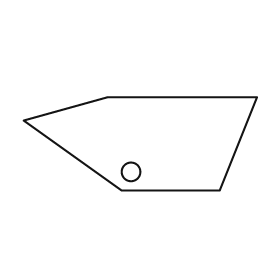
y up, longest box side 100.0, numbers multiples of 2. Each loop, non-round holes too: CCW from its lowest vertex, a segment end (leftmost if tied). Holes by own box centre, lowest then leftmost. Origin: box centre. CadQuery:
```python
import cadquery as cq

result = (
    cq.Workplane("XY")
    .moveTo(-8.0, -20.0)
    .lineTo(34.0, -20.0)
    .lineTo(50.0, 20.0)
    .lineTo(-14.0, 20.0)
    .lineTo(-50.0, 10.0)
    .close()
    .moveTo(-4.0, -12.0)
    .circle(4.0)
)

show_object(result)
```